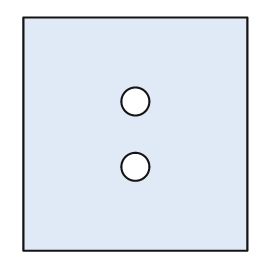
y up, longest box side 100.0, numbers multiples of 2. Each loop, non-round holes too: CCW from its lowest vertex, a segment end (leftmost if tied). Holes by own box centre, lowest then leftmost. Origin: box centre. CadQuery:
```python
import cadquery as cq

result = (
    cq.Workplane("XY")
    .moveTo(-48.0, -50.0)
    .lineTo(48.0, -50.0)
    .lineTo(48.0, 50.0)
    .lineTo(-48.0, 50.0)
    .close()
    .moveTo(0.0, -14.0)
    .circle(6.0)
    .moveTo(0.0, 14.0)
    .circle(6.0)
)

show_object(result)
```